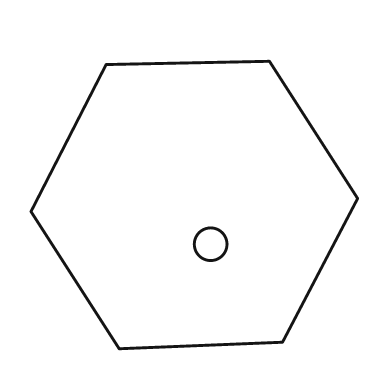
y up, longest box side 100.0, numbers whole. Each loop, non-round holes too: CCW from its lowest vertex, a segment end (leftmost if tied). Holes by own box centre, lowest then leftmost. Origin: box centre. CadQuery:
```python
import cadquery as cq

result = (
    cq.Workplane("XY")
    .moveTo(-23.0, -44.0)
    .lineTo(27.0, -42.0)
    .lineTo(50.0, 2.0)
    .lineTo(23.0, 44.0)
    .lineTo(-27.0, 43.0)
    .lineTo(-50.0, -2.0)
    .close()
    .moveTo(5.0, -12.0)
    .circle(5.0)
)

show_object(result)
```